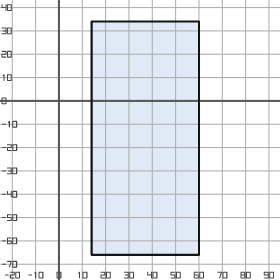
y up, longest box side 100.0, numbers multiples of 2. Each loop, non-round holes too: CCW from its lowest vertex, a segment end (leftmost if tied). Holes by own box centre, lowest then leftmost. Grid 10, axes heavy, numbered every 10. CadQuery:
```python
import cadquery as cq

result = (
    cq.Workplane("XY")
    .moveTo(14.0, -66.0)
    .lineTo(60.0, -66.0)
    .lineTo(60.0, 34.0)
    .lineTo(14.0, 34.0)
    .close()
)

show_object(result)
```